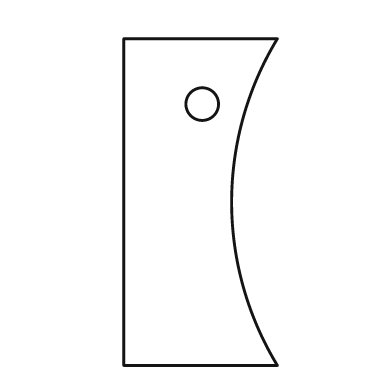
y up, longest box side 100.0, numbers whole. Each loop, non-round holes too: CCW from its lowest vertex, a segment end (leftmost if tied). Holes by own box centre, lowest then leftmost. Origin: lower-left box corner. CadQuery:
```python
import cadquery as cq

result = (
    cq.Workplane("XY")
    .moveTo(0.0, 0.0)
    .lineTo(47.0, 0.0)
    .threePointArc((33.0, 50.0), (47.0, 100.0))
    .lineTo(0.0, 100.0)
    .close()
    .moveTo(24.0, 80.0)
    .circle(5.0)
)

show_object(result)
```